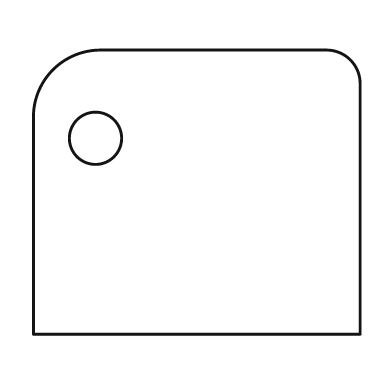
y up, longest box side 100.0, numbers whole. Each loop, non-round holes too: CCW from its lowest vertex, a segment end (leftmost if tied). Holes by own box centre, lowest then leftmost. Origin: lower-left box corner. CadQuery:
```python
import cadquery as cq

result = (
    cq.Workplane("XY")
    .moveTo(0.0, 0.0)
    .lineTo(100.0, 0.0)
    .lineTo(100.0, 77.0)
    .threePointArc((97.0, 84.0), (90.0, 87.0))
    .lineTo(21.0, 87.0)
    .threePointArc((6.0, 81.0), (0.0, 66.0))
    .close()
    .moveTo(19.0, 60.0)
    .circle(8.0)
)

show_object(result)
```